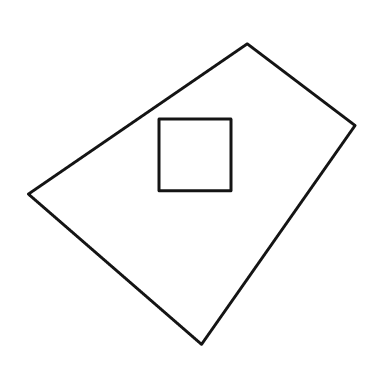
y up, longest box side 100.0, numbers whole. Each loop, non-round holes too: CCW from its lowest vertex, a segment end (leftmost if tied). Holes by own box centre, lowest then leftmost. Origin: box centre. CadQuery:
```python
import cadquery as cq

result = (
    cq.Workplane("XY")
    .moveTo(3.0, -46.0)
    .lineTo(50.0, 21.0)
    .lineTo(17.0, 46.0)
    .lineTo(-50.0, 0.0)
    .close()
    .moveTo(-10.0, 1.0)
    .lineTo(12.0, 1.0)
    .lineTo(12.0, 23.0)
    .lineTo(-10.0, 23.0)
    .close()
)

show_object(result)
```